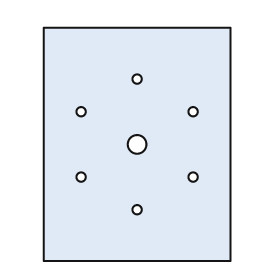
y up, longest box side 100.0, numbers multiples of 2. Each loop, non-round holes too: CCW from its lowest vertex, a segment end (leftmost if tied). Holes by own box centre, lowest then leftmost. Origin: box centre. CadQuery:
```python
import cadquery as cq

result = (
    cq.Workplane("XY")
    .moveTo(-40.0, -50.0)
    .lineTo(40.0, -50.0)
    .lineTo(40.0, 50.0)
    .lineTo(-40.0, 50.0)
    .close()
    .moveTo(0.0, -28.0)
    .circle(2.0)
    .moveTo(-24.0, -14.0)
    .circle(2.0)
    .moveTo(24.0, -14.0)
    .circle(2.0)
    .moveTo(0.0, 0.0)
    .circle(4.0)
    .moveTo(-24.0, 14.0)
    .circle(2.0)
    .moveTo(24.0, 14.0)
    .circle(2.0)
    .moveTo(0.0, 28.0)
    .circle(2.0)
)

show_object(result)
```